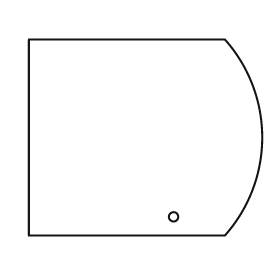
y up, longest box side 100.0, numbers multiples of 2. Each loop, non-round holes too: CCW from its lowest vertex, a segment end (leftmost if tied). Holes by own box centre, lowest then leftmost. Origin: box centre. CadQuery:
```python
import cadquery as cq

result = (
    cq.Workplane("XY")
    .moveTo(-50.0, -42.0)
    .lineTo(34.0, -42.0)
    .threePointArc((50.0, 0.0), (34.0, 42.0))
    .lineTo(-50.0, 42.0)
    .close()
    .moveTo(12.0, -34.0)
    .circle(2.0)
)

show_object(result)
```